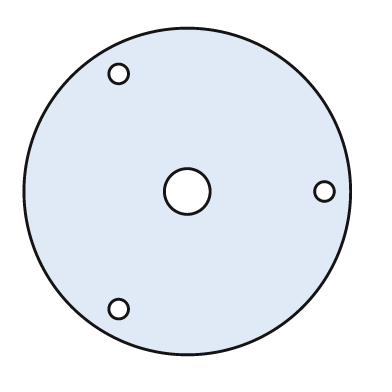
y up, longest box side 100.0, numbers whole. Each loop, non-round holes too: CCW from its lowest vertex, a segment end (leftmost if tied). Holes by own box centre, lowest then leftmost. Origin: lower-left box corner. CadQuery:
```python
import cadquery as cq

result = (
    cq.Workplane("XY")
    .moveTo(50.0, 50.0)
    .circle(50.0)
    .moveTo(29.0, 14.0)
    .circle(3.0)
    .moveTo(50.0, 50.0)
    .circle(7.0)
    .moveTo(92.0, 50.0)
    .circle(3.0)
    .moveTo(29.0, 86.0)
    .circle(3.0)
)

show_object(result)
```